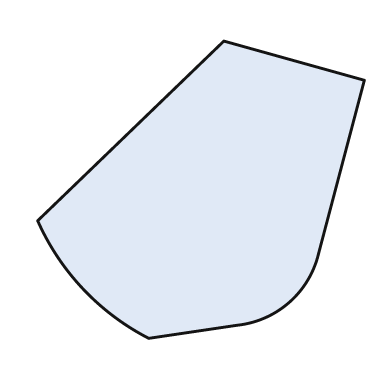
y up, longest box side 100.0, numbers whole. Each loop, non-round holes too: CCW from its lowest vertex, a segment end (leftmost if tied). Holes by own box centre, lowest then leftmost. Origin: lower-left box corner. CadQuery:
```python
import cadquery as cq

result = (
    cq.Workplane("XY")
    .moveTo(34.0, 0.0)
    .lineTo(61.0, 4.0)
    .threePointArc((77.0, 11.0), (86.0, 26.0))
    .lineTo(100.0, 79.0)
    .lineTo(57.0, 91.0)
    .lineTo(0.0, 36.0)
    .threePointArc((14.0, 15.0), (34.0, 0.0))
    .close()
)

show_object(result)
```